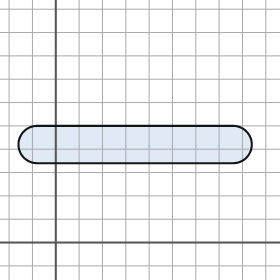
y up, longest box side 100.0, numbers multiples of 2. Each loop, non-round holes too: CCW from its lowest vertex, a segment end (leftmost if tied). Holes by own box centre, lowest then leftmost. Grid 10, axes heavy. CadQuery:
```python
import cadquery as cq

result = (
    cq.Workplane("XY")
    .moveTo(-8.0, 34.0)
    .lineTo(76.0, 34.0)
    .threePointArc((84.0, 42.0), (76.0, 50.0))
    .lineTo(-8.0, 50.0)
    .threePointArc((-16.0, 42.0), (-8.0, 34.0))
    .close()
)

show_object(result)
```